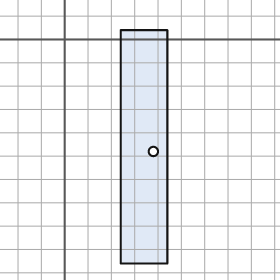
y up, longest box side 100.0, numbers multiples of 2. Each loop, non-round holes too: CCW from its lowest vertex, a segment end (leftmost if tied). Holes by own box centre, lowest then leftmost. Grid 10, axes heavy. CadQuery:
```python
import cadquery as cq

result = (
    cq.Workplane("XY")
    .moveTo(24.0, -96.0)
    .lineTo(44.0, -96.0)
    .lineTo(44.0, 4.0)
    .lineTo(24.0, 4.0)
    .close()
    .moveTo(38.0, -48.0)
    .circle(2.0)
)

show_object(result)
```